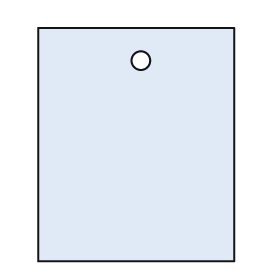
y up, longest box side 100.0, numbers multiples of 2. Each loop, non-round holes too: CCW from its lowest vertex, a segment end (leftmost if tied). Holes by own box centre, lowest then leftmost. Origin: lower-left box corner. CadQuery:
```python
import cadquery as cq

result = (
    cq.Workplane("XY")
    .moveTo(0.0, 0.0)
    .lineTo(84.0, 0.0)
    .lineTo(84.0, 100.0)
    .lineTo(0.0, 100.0)
    .close()
    .moveTo(44.0, 86.0)
    .circle(4.0)
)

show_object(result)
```